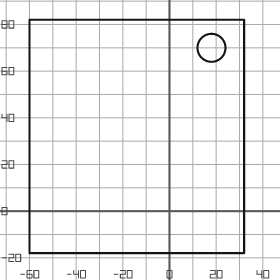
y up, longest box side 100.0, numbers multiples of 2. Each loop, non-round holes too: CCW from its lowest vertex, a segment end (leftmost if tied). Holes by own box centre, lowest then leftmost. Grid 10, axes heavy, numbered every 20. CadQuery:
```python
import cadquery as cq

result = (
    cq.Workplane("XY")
    .moveTo(-60.0, -18.0)
    .lineTo(32.0, -18.0)
    .lineTo(32.0, 82.0)
    .lineTo(-60.0, 82.0)
    .close()
    .moveTo(18.0, 70.0)
    .circle(6.0)
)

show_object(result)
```